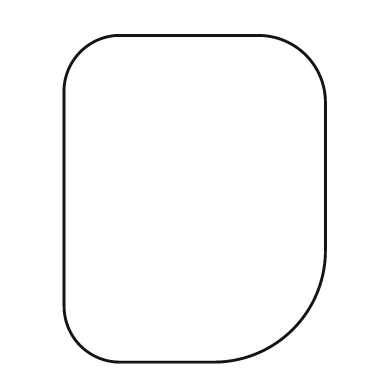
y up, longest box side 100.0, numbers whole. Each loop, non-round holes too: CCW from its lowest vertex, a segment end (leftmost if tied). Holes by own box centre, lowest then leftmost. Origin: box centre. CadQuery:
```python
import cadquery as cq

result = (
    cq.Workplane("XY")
    .moveTo(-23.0, -50.0)
    .lineTo(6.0, -50.0)
    .threePointArc((30.0, -40.0), (40.0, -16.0))
    .lineTo(40.0, 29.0)
    .threePointArc((34.0, 44.0), (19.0, 50.0))
    .lineTo(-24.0, 50.0)
    .threePointArc((-35.0, 45.0), (-40.0, 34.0))
    .lineTo(-40.0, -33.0)
    .threePointArc((-35.0, -45.0), (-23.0, -50.0))
    .close()
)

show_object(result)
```